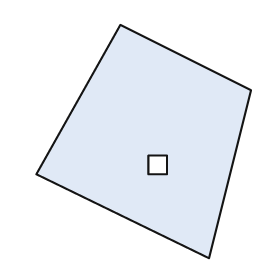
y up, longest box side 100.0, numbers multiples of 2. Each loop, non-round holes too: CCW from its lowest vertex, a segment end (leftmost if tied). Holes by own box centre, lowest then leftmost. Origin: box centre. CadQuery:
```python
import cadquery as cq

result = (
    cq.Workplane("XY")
    .moveTo(28.0, -50.0)
    .lineTo(46.0, 22.0)
    .lineTo(-10.0, 50.0)
    .lineTo(-46.0, -14.0)
    .close()
    .moveTo(2.0, -14.0)
    .lineTo(10.0, -14.0)
    .lineTo(10.0, -6.0)
    .lineTo(2.0, -6.0)
    .close()
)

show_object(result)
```